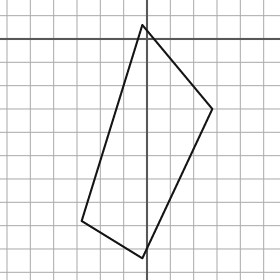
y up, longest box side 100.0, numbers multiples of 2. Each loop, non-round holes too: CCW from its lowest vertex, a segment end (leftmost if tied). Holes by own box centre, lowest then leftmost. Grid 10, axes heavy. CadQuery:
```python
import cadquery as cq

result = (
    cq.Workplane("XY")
    .moveTo(-2.0, -94.0)
    .lineTo(28.0, -30.0)
    .lineTo(-2.0, 6.0)
    .lineTo(-28.0, -78.0)
    .close()
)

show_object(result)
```